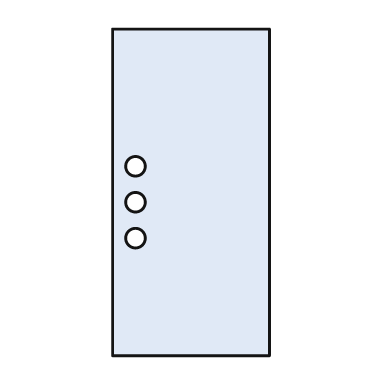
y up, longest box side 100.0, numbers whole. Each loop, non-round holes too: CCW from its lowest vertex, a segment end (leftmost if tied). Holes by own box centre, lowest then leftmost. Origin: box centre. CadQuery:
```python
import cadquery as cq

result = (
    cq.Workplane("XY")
    .moveTo(-24.0, -50.0)
    .lineTo(24.0, -50.0)
    .lineTo(24.0, 50.0)
    .lineTo(-24.0, 50.0)
    .close()
    .moveTo(-17.0, -14.0)
    .circle(3.0)
    .moveTo(-17.0, -3.0)
    .circle(3.0)
    .moveTo(-17.0, 8.0)
    .circle(3.0)
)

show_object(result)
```